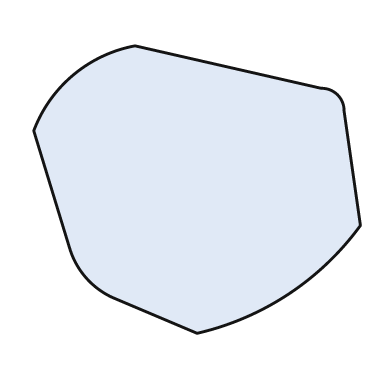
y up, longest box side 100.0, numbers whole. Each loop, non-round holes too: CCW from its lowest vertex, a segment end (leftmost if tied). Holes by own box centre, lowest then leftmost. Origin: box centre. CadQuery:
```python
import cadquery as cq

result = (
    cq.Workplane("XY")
    .moveTo(0.0, -44.0)
    .threePointArc((28.0, -32.0), (50.0, -11.0))
    .lineTo(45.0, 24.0)
    .threePointArc((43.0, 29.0), (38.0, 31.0))
    .lineTo(-19.0, 44.0)
    .threePointArc((-38.0, 35.0), (-50.0, 18.0))
    .lineTo(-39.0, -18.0)
    .threePointArc((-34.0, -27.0), (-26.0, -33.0))
    .close()
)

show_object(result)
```